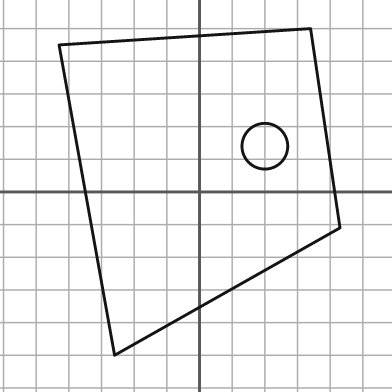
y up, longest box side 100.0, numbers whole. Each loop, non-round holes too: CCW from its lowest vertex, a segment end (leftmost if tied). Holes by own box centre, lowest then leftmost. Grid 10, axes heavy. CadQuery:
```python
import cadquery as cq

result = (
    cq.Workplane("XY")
    .moveTo(-26.0, -50.0)
    .lineTo(43.0, -11.0)
    .lineTo(34.0, 50.0)
    .lineTo(-43.0, 45.0)
    .close()
    .moveTo(20.0, 14.0)
    .circle(7.0)
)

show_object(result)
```